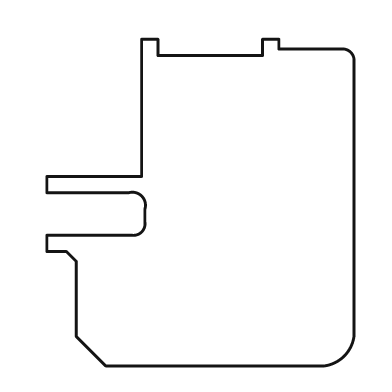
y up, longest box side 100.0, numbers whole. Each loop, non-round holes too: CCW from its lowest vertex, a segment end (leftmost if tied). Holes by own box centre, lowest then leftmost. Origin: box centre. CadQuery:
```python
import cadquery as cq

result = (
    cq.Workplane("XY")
    .moveTo(-29.0, -50.0)
    .lineTo(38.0, -50.0)
    .threePointArc((44.0, -47.0), (47.0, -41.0))
    .lineTo(47.0, 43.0)
    .threePointArc((46.0, 46.0), (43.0, 47.0))
    .lineTo(24.0, 47.0)
    .lineTo(24.0, 50.0)
    .lineTo(19.0, 50.0)
    .lineTo(19.0, 45.0)
    .lineTo(-13.0, 45.0)
    .lineTo(-13.0, 50.0)
    .lineTo(-18.0, 50.0)
    .lineTo(-18.0, 8.0)
    .lineTo(-47.0, 8.0)
    .lineTo(-47.0, 3.0)
    .lineTo(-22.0, 3.0)
    .threePointArc((-18.0, 2.0), (-17.0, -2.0))
    .lineTo(-17.0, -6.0)
    .threePointArc((-18.0, -9.0), (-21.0, -10.0))
    .lineTo(-47.0, -10.0)
    .lineTo(-47.0, -15.0)
    .lineTo(-41.0, -15.0)
    .lineTo(-38.0, -18.0)
    .lineTo(-38.0, -41.0)
    .close()
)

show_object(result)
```